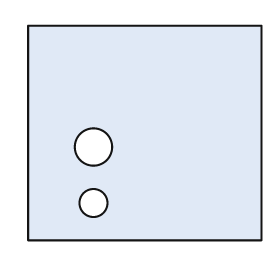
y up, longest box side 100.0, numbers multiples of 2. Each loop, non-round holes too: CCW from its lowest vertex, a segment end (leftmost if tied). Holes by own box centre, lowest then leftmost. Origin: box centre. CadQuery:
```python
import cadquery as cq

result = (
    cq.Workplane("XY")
    .moveTo(-50.0, -46.0)
    .lineTo(50.0, -46.0)
    .lineTo(50.0, 46.0)
    .lineTo(-50.0, 46.0)
    .close()
    .moveTo(-22.0, -30.0)
    .circle(6.0)
    .moveTo(-22.0, -6.0)
    .circle(8.0)
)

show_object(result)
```